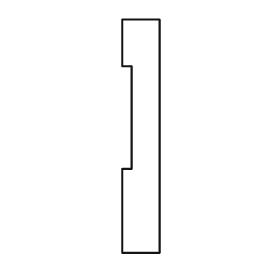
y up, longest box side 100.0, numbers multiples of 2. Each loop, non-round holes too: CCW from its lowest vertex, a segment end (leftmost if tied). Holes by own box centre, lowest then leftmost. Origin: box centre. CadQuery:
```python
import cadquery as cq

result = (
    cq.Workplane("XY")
    .moveTo(-8.0, -50.0)
    .lineTo(8.0, -50.0)
    .lineTo(8.0, 50.0)
    .lineTo(-8.0, 50.0)
    .lineTo(-8.0, 30.0)
    .lineTo(-4.0, 30.0)
    .lineTo(-4.0, -14.0)
    .lineTo(-8.0, -14.0)
    .close()
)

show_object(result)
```